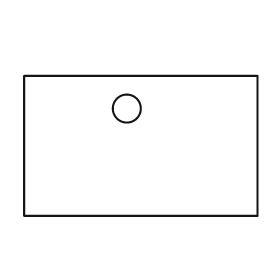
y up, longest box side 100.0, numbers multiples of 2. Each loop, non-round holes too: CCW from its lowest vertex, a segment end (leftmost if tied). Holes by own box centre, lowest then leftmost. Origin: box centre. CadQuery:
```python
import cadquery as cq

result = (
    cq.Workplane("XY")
    .moveTo(-50.0, -30.0)
    .lineTo(50.0, -30.0)
    .lineTo(50.0, 30.0)
    .lineTo(-50.0, 30.0)
    .close()
    .moveTo(-6.0, 16.0)
    .circle(6.0)
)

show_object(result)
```